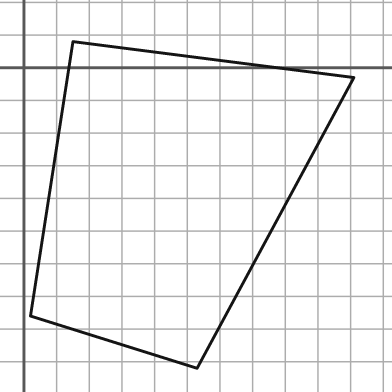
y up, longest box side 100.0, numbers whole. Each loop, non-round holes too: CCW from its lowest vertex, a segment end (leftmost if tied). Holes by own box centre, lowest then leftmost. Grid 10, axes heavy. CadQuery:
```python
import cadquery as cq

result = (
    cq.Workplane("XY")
    .moveTo(53.0, -92.0)
    .lineTo(101.0, -3.0)
    .lineTo(15.0, 8.0)
    .lineTo(2.0, -76.0)
    .close()
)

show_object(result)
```